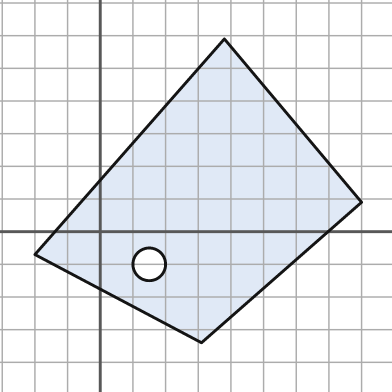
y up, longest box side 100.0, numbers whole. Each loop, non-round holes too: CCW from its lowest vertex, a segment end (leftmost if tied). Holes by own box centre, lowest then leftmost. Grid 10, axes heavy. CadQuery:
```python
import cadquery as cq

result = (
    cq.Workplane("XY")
    .moveTo(31.0, -34.0)
    .lineTo(80.0, 9.0)
    .lineTo(38.0, 59.0)
    .lineTo(-20.0, -7.0)
    .close()
    .moveTo(15.0, -10.0)
    .circle(5.0)
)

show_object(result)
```